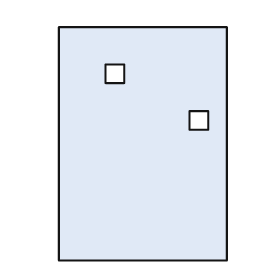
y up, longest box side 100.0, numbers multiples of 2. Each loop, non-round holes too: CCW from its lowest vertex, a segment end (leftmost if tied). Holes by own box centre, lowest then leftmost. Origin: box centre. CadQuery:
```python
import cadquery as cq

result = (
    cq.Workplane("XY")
    .moveTo(-36.0, -50.0)
    .lineTo(36.0, -50.0)
    .lineTo(36.0, 50.0)
    .lineTo(-36.0, 50.0)
    .close()
    .moveTo(20.0, 6.0)
    .lineTo(28.0, 6.0)
    .lineTo(28.0, 14.0)
    .lineTo(20.0, 14.0)
    .close()
    .moveTo(-16.0, 26.0)
    .lineTo(-8.0, 26.0)
    .lineTo(-8.0, 34.0)
    .lineTo(-16.0, 34.0)
    .close()
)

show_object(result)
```